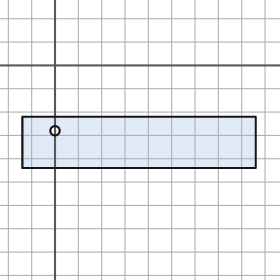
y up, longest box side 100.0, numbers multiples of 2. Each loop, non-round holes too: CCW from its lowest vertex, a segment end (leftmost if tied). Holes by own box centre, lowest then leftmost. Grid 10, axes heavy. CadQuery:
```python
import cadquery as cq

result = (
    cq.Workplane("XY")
    .moveTo(-14.0, -44.0)
    .lineTo(86.0, -44.0)
    .lineTo(86.0, -22.0)
    .lineTo(-14.0, -22.0)
    .close()
    .moveTo(0.0, -28.0)
    .circle(2.0)
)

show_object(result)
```